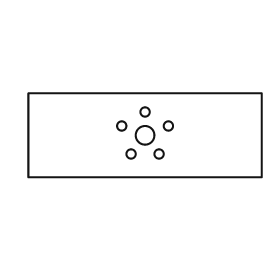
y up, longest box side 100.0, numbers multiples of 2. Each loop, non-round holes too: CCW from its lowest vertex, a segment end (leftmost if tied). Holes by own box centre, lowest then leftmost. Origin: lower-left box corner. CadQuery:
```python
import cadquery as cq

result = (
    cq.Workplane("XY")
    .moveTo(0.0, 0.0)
    .lineTo(100.0, 0.0)
    .lineTo(100.0, 36.0)
    .lineTo(0.0, 36.0)
    .close()
    .moveTo(44.0, 10.0)
    .circle(2.0)
    .moveTo(56.0, 10.0)
    .circle(2.0)
    .moveTo(50.0, 18.0)
    .circle(4.0)
    .moveTo(40.0, 22.0)
    .circle(2.0)
    .moveTo(60.0, 22.0)
    .circle(2.0)
    .moveTo(50.0, 28.0)
    .circle(2.0)
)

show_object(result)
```